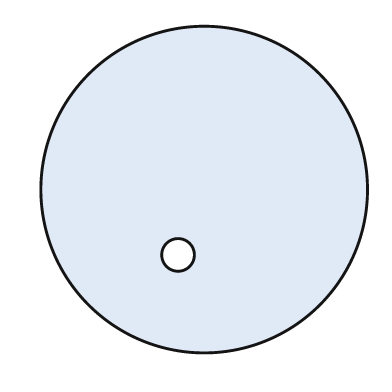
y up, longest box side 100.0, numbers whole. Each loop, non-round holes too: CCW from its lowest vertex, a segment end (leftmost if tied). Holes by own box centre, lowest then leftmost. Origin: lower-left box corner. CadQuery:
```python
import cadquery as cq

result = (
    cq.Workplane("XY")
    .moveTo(50.0, 50.0)
    .circle(50.0)
    .moveTo(42.0, 30.0)
    .circle(5.0)
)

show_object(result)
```